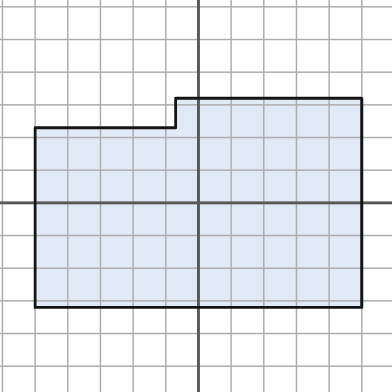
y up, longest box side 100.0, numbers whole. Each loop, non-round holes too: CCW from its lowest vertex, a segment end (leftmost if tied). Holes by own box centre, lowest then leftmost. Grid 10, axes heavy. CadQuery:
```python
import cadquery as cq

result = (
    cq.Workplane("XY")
    .moveTo(-50.0, -32.0)
    .lineTo(50.0, -32.0)
    .lineTo(50.0, 32.0)
    .lineTo(-7.0, 32.0)
    .lineTo(-7.0, 23.0)
    .lineTo(-50.0, 23.0)
    .close()
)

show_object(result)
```